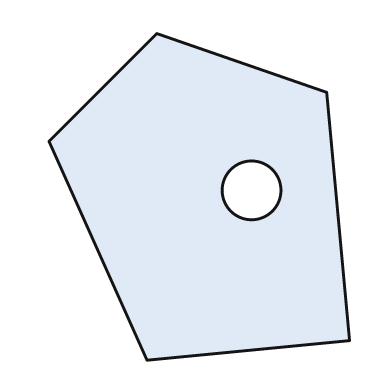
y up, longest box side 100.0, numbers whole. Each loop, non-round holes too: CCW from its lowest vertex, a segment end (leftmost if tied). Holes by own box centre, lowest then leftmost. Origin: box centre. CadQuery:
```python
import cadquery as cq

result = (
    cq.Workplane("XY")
    .moveTo(-16.0, -50.0)
    .lineTo(46.0, -44.0)
    .lineTo(39.0, 32.0)
    .lineTo(-13.0, 50.0)
    .lineTo(-46.0, 17.0)
    .close()
    .moveTo(16.0, 2.0)
    .circle(9.0)
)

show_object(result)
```